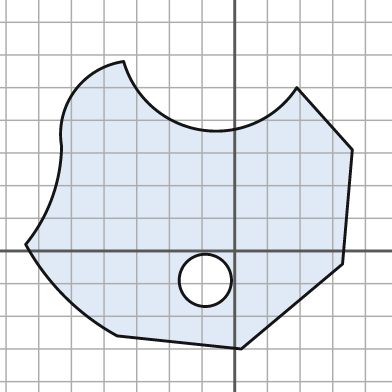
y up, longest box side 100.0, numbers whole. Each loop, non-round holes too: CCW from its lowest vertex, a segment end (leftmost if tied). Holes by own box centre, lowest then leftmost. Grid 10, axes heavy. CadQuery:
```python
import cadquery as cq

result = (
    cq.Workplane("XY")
    .moveTo(2.0, -30.0)
    .lineTo(33.0, -4.0)
    .lineTo(36.0, 31.0)
    .lineTo(19.0, 50.0)
    .threePointArc((-10.0, 37.0), (-34.0, 58.0))
    .threePointArc((-49.0, 49.0), (-53.0, 32.0))
    .threePointArc((-56.0, 16.0), (-64.0, 2.0))
    .threePointArc((-52.0, -14.0), (-36.0, -26.0))
    .close()
    .moveTo(-9.0, -9.0)
    .circle(8.0)
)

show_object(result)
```